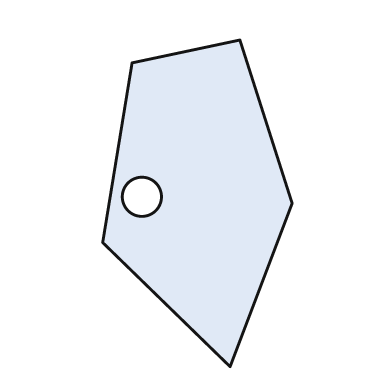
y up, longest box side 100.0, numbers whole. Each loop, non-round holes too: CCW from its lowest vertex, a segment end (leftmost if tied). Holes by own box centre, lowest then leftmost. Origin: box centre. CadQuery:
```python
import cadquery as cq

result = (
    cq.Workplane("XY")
    .moveTo(10.0, -50.0)
    .lineTo(29.0, 0.0)
    .lineTo(13.0, 50.0)
    .lineTo(-20.0, 43.0)
    .lineTo(-29.0, -12.0)
    .close()
    .moveTo(-17.0, 2.0)
    .circle(6.0)
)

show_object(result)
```